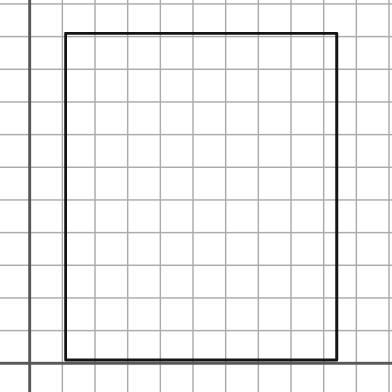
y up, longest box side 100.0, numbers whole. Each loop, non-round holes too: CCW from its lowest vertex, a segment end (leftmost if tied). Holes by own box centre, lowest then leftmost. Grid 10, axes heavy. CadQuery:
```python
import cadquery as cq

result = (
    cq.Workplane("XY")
    .moveTo(11.0, 1.0)
    .lineTo(94.0, 1.0)
    .lineTo(94.0, 101.0)
    .lineTo(11.0, 101.0)
    .close()
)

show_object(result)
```